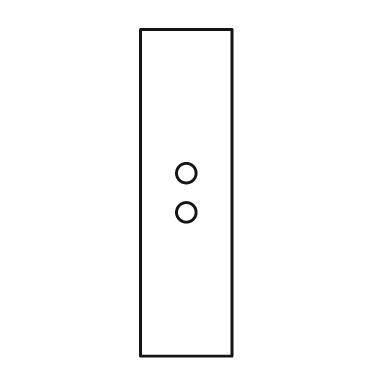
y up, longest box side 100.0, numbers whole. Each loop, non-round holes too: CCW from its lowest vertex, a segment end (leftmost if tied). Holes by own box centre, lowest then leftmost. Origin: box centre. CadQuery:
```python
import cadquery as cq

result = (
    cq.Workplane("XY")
    .moveTo(-14.0, -50.0)
    .lineTo(14.0, -50.0)
    .lineTo(14.0, 50.0)
    .lineTo(-14.0, 50.0)
    .close()
    .moveTo(0.0, -6.0)
    .circle(3.0)
    .moveTo(0.0, 6.0)
    .circle(3.0)
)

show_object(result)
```